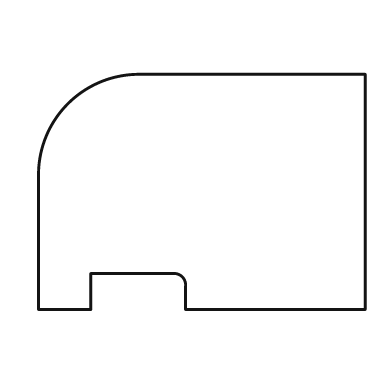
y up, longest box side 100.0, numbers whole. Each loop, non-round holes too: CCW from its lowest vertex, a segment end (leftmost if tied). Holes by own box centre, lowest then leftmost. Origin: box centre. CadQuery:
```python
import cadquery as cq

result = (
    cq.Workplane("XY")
    .moveTo(-50.0, -36.0)
    .lineTo(-34.0, -36.0)
    .lineTo(-34.0, -25.0)
    .lineTo(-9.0, -25.0)
    .threePointArc((-6.0, -26.0), (-5.0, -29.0))
    .lineTo(-5.0, -36.0)
    .lineTo(50.0, -36.0)
    .lineTo(50.0, 36.0)
    .lineTo(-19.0, 36.0)
    .threePointArc((-41.0, 27.0), (-50.0, 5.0))
    .close()
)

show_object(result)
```